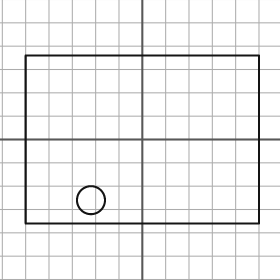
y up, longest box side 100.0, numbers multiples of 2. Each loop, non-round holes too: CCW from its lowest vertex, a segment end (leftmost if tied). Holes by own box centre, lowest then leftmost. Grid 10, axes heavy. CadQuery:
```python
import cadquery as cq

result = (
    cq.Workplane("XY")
    .moveTo(-50.0, -36.0)
    .lineTo(50.0, -36.0)
    .lineTo(50.0, 36.0)
    .lineTo(-50.0, 36.0)
    .close()
    .moveTo(-22.0, -26.0)
    .circle(6.0)
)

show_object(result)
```